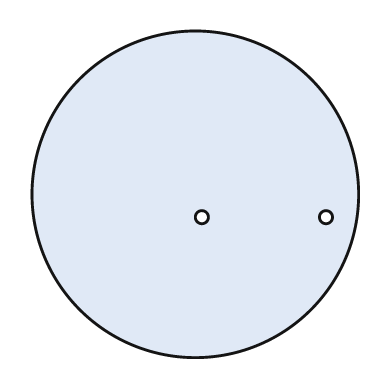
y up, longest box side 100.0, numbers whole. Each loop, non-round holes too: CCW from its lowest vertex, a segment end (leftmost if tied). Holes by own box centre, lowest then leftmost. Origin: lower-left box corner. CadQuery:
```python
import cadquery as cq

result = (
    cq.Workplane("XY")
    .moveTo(50.0, 50.0)
    .circle(50.0)
    .moveTo(52.0, 43.0)
    .circle(2.0)
    .moveTo(90.0, 43.0)
    .circle(2.0)
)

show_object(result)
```